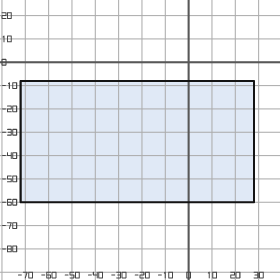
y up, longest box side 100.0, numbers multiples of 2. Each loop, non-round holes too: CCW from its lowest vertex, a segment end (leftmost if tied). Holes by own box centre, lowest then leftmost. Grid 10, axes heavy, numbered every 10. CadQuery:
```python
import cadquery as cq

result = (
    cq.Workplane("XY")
    .moveTo(-72.0, -60.0)
    .lineTo(28.0, -60.0)
    .lineTo(28.0, -8.0)
    .lineTo(-72.0, -8.0)
    .close()
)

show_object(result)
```